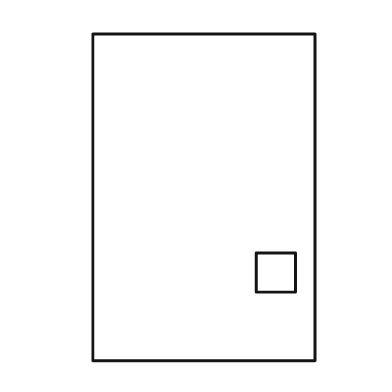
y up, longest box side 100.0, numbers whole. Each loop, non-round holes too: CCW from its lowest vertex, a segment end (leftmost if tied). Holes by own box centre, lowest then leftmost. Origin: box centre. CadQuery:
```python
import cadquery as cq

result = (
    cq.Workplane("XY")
    .moveTo(-34.0, -50.0)
    .lineTo(34.0, -50.0)
    .lineTo(34.0, 50.0)
    .lineTo(-34.0, 50.0)
    .close()
    .moveTo(16.0, -29.0)
    .lineTo(28.0, -29.0)
    .lineTo(28.0, -17.0)
    .lineTo(16.0, -17.0)
    .close()
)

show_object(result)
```